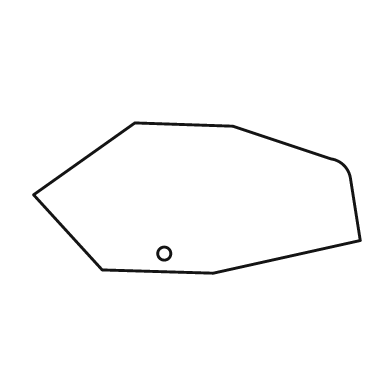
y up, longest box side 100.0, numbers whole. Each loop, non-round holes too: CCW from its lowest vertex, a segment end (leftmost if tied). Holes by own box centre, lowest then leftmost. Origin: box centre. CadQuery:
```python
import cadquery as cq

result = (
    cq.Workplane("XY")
    .moveTo(5.0, -23.0)
    .lineTo(50.0, -13.0)
    .lineTo(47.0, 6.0)
    .threePointArc((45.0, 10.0), (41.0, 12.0))
    .lineTo(11.0, 22.0)
    .lineTo(-19.0, 23.0)
    .lineTo(-50.0, 1.0)
    .lineTo(-29.0, -22.0)
    .close()
    .moveTo(-10.0, -17.0)
    .circle(2.0)
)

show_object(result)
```